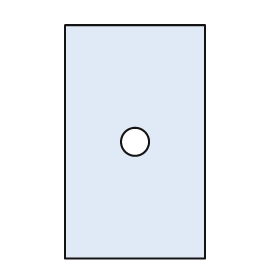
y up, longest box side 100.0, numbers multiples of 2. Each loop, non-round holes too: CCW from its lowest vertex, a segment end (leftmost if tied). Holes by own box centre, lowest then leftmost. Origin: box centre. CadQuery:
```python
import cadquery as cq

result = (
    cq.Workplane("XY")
    .moveTo(-30.0, -50.0)
    .lineTo(30.0, -50.0)
    .lineTo(30.0, 50.0)
    .lineTo(-30.0, 50.0)
    .close()
    .moveTo(0.0, 0.0)
    .circle(6.0)
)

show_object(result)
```